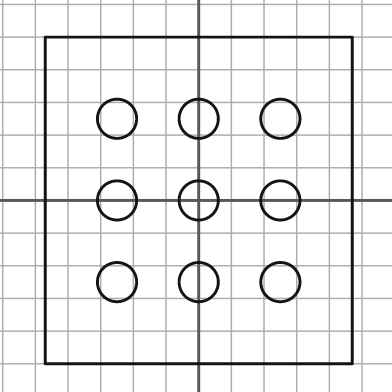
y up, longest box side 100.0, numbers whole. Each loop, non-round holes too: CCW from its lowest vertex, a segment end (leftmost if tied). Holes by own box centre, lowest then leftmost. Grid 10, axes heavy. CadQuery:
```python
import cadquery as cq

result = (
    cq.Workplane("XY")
    .moveTo(-47.0, -50.0)
    .lineTo(47.0, -50.0)
    .lineTo(47.0, 50.0)
    .lineTo(-47.0, 50.0)
    .close()
    .moveTo(-25.0, -25.0)
    .circle(6.0)
    .moveTo(0.0, -25.0)
    .circle(6.0)
    .moveTo(25.0, -25.0)
    .circle(6.0)
    .moveTo(-25.0, 0.0)
    .circle(6.0)
    .moveTo(0.0, 0.0)
    .circle(6.0)
    .moveTo(25.0, 0.0)
    .circle(6.0)
    .moveTo(-25.0, 25.0)
    .circle(6.0)
    .moveTo(0.0, 25.0)
    .circle(6.0)
    .moveTo(25.0, 25.0)
    .circle(6.0)
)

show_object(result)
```